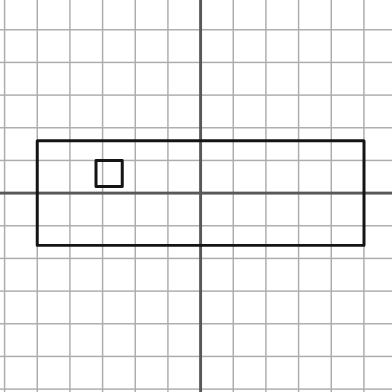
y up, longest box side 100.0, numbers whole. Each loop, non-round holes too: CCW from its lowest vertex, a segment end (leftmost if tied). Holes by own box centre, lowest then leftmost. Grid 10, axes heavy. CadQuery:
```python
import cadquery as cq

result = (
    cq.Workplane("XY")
    .moveTo(-50.0, -16.0)
    .lineTo(50.0, -16.0)
    .lineTo(50.0, 16.0)
    .lineTo(-50.0, 16.0)
    .close()
    .moveTo(-32.0, 2.0)
    .lineTo(-24.0, 2.0)
    .lineTo(-24.0, 10.0)
    .lineTo(-32.0, 10.0)
    .close()
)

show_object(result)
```